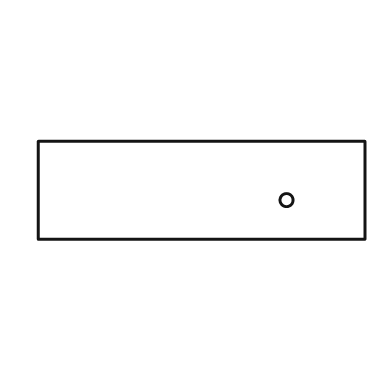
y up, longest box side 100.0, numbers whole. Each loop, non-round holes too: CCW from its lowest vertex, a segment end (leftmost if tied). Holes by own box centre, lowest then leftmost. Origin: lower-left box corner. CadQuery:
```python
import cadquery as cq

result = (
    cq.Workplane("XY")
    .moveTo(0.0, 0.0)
    .lineTo(100.0, 0.0)
    .lineTo(100.0, 30.0)
    .lineTo(0.0, 30.0)
    .close()
    .moveTo(76.0, 12.0)
    .circle(2.0)
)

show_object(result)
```